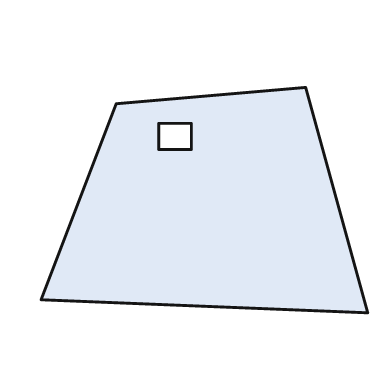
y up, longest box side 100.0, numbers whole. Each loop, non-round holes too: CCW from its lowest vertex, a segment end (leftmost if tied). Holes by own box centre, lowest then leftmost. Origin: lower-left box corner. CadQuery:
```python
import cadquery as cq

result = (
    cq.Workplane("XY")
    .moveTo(100.0, 0.0)
    .lineTo(81.0, 69.0)
    .lineTo(23.0, 64.0)
    .lineTo(0.0, 4.0)
    .close()
    .moveTo(36.0, 50.0)
    .lineTo(46.0, 50.0)
    .lineTo(46.0, 58.0)
    .lineTo(36.0, 58.0)
    .close()
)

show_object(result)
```